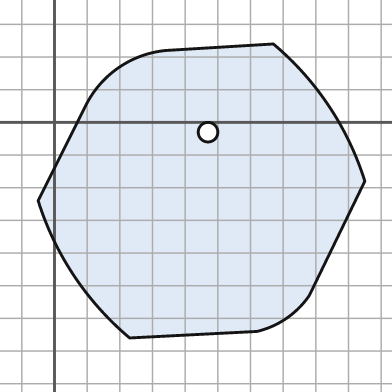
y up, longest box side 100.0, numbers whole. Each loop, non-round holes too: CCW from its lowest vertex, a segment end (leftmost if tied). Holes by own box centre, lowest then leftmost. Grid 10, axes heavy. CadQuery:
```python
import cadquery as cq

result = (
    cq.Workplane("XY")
    .moveTo(23.0, -66.0)
    .lineTo(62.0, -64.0)
    .threePointArc((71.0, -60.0), (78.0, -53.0))
    .lineTo(95.0, -18.0)
    .threePointArc((84.0, 5.0), (67.0, 24.0))
    .lineTo(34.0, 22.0)
    .threePointArc((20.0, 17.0), (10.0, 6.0))
    .lineTo(-5.0, -24.0)
    .threePointArc((6.0, -47.0), (23.0, -66.0))
    .close()
    .moveTo(47.0, -3.0)
    .circle(3.0)
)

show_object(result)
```